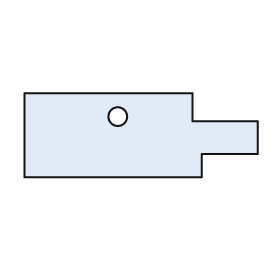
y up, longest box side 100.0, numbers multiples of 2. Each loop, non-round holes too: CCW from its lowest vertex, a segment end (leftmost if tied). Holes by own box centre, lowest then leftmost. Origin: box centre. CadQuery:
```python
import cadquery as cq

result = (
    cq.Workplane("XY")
    .moveTo(-50.0, -18.0)
    .lineTo(26.0, -18.0)
    .lineTo(26.0, -8.0)
    .lineTo(50.0, -8.0)
    .lineTo(50.0, 6.0)
    .lineTo(22.0, 6.0)
    .lineTo(22.0, 18.0)
    .lineTo(-50.0, 18.0)
    .close()
    .moveTo(-10.0, 8.0)
    .circle(4.0)
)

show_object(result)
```